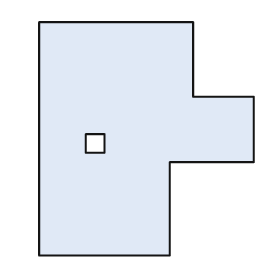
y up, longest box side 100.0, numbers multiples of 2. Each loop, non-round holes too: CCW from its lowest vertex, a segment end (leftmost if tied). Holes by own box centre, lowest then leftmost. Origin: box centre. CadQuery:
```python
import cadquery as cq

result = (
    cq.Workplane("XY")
    .moveTo(-46.0, -50.0)
    .lineTo(10.0, -50.0)
    .lineTo(10.0, -10.0)
    .lineTo(46.0, -10.0)
    .lineTo(46.0, 18.0)
    .lineTo(20.0, 18.0)
    .lineTo(20.0, 50.0)
    .lineTo(-46.0, 50.0)
    .close()
    .moveTo(-26.0, -6.0)
    .lineTo(-18.0, -6.0)
    .lineTo(-18.0, 2.0)
    .lineTo(-26.0, 2.0)
    .close()
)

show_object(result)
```